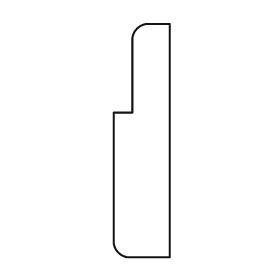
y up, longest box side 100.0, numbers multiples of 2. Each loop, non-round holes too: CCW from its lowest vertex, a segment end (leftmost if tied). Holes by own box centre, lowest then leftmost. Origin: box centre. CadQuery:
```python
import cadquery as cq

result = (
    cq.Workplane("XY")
    .moveTo(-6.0, -50.0)
    .lineTo(12.0, -50.0)
    .lineTo(12.0, 50.0)
    .lineTo(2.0, 50.0)
    .threePointArc((-2.0, 48.0), (-4.0, 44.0))
    .lineTo(-4.0, 12.0)
    .lineTo(-12.0, 12.0)
    .lineTo(-12.0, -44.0)
    .threePointArc((-10.0, -48.0), (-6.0, -50.0))
    .close()
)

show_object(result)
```